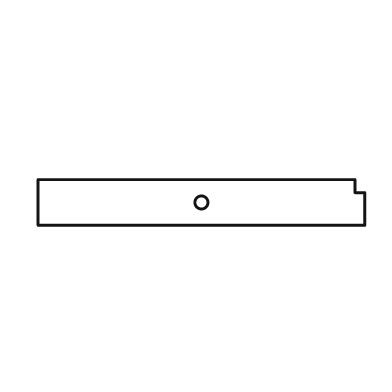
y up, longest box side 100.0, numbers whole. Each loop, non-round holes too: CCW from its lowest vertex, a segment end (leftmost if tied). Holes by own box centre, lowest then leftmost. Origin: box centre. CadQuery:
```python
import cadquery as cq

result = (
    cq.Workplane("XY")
    .moveTo(-50.0, -7.0)
    .lineTo(50.0, -7.0)
    .lineTo(50.0, 3.0)
    .lineTo(47.0, 3.0)
    .lineTo(47.0, 7.0)
    .lineTo(-50.0, 7.0)
    .close()
    .moveTo(0.0, 0.0)
    .circle(2.0)
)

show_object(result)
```